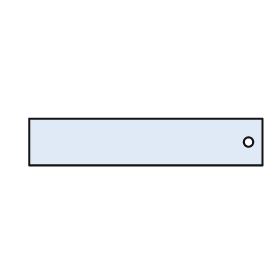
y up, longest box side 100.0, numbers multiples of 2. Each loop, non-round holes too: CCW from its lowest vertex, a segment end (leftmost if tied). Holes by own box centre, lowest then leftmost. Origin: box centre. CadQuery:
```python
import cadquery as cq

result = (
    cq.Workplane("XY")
    .moveTo(-50.0, -10.0)
    .lineTo(50.0, -10.0)
    .lineTo(50.0, 10.0)
    .lineTo(-50.0, 10.0)
    .close()
    .moveTo(44.0, 0.0)
    .circle(2.0)
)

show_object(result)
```